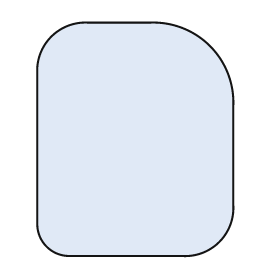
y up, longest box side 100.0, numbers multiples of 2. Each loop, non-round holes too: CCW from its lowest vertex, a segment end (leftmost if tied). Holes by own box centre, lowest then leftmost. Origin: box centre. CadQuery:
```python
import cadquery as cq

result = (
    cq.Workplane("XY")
    .moveTo(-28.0, -50.0)
    .lineTo(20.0, -50.0)
    .threePointArc((36.0, -44.0), (42.0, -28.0))
    .lineTo(42.0, 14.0)
    .threePointArc((32.0, 40.0), (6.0, 50.0))
    .lineTo(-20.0, 50.0)
    .threePointArc((-36.0, 44.0), (-42.0, 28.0))
    .lineTo(-42.0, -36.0)
    .threePointArc((-38.0, -46.0), (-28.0, -50.0))
    .close()
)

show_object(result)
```